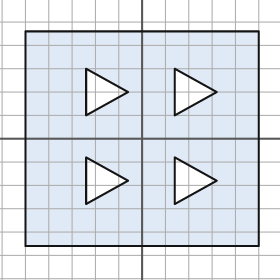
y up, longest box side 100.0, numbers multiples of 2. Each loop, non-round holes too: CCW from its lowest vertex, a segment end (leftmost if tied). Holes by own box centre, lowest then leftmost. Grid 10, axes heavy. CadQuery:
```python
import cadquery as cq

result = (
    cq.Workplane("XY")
    .moveTo(-50.0, -46.0)
    .lineTo(50.0, -46.0)
    .lineTo(50.0, 46.0)
    .lineTo(-50.0, 46.0)
    .close()
    .moveTo(-24.0, -28.0)
    .lineTo(-6.0, -18.0)
    .lineTo(-24.0, -8.0)
    .close()
    .moveTo(14.0, -28.0)
    .lineTo(32.0, -18.0)
    .lineTo(14.0, -8.0)
    .close()
    .moveTo(-24.0, 10.0)
    .lineTo(-6.0, 20.0)
    .lineTo(-24.0, 30.0)
    .close()
    .moveTo(14.0, 10.0)
    .lineTo(32.0, 20.0)
    .lineTo(14.0, 30.0)
    .close()
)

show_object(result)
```